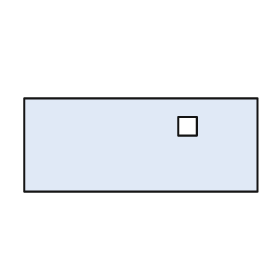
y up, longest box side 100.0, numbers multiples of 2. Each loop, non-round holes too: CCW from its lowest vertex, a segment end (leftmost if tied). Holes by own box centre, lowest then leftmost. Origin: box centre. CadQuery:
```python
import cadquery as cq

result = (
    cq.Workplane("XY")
    .moveTo(-50.0, -20.0)
    .lineTo(50.0, -20.0)
    .lineTo(50.0, 20.0)
    .lineTo(-50.0, 20.0)
    .close()
    .moveTo(16.0, 4.0)
    .lineTo(24.0, 4.0)
    .lineTo(24.0, 12.0)
    .lineTo(16.0, 12.0)
    .close()
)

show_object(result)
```